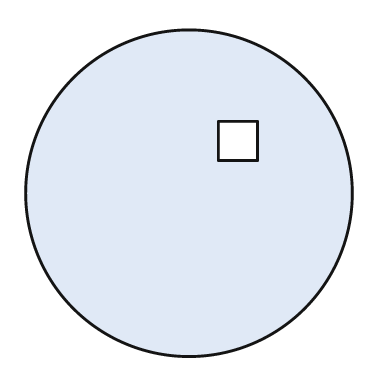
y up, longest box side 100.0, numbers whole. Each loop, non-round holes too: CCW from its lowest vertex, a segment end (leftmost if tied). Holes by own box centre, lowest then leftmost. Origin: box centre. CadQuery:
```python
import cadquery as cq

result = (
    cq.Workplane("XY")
    .moveTo(0.0, 0.0)
    .circle(50.0)
    .moveTo(9.0, 10.0)
    .lineTo(21.0, 10.0)
    .lineTo(21.0, 22.0)
    .lineTo(9.0, 22.0)
    .close()
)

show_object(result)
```